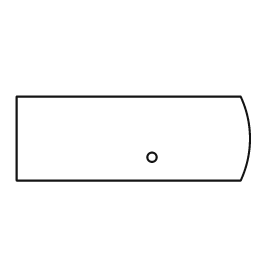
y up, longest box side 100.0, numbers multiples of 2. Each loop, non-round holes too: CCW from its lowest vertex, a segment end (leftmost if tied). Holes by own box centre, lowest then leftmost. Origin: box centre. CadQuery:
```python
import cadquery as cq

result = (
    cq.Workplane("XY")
    .moveTo(-50.0, -18.0)
    .lineTo(46.0, -18.0)
    .threePointArc((50.0, 0.0), (46.0, 18.0))
    .lineTo(-50.0, 18.0)
    .close()
    .moveTo(8.0, -8.0)
    .circle(2.0)
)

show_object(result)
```